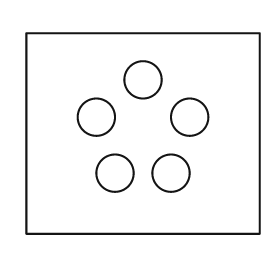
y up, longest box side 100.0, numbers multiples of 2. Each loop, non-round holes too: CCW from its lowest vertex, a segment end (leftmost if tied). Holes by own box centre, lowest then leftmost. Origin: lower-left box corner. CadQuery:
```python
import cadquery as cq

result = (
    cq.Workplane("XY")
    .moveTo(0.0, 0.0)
    .lineTo(100.0, 0.0)
    .lineTo(100.0, 86.0)
    .lineTo(0.0, 86.0)
    .close()
    .moveTo(38.0, 26.0)
    .circle(8.0)
    .moveTo(62.0, 26.0)
    .circle(8.0)
    .moveTo(30.0, 50.0)
    .circle(8.0)
    .moveTo(70.0, 50.0)
    .circle(8.0)
    .moveTo(50.0, 66.0)
    .circle(8.0)
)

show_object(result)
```